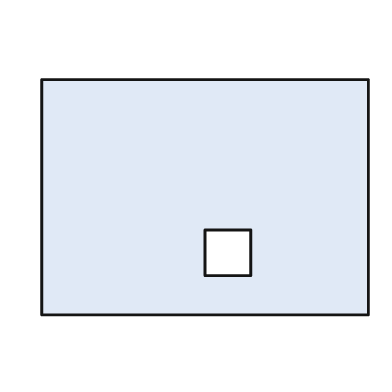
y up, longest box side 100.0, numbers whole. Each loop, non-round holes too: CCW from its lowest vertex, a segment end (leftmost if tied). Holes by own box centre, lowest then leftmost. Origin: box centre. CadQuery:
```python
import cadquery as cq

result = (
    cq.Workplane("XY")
    .moveTo(-50.0, -36.0)
    .lineTo(50.0, -36.0)
    .lineTo(50.0, 36.0)
    .lineTo(-50.0, 36.0)
    .close()
    .moveTo(0.0, -24.0)
    .lineTo(14.0, -24.0)
    .lineTo(14.0, -10.0)
    .lineTo(0.0, -10.0)
    .close()
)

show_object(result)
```